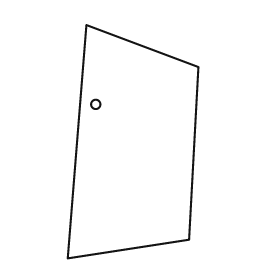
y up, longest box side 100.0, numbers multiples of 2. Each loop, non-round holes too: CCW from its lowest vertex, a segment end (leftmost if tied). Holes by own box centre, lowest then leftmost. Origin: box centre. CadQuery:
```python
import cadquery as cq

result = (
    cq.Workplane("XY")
    .moveTo(-28.0, -50.0)
    .lineTo(24.0, -42.0)
    .lineTo(28.0, 32.0)
    .lineTo(-20.0, 50.0)
    .close()
    .moveTo(-16.0, 16.0)
    .circle(2.0)
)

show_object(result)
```